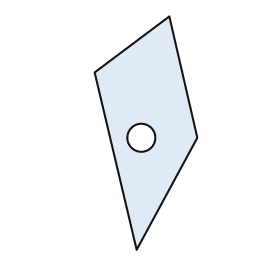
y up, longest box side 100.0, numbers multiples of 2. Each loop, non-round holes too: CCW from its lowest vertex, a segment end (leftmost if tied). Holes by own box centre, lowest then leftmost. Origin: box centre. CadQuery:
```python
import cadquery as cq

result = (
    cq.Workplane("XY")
    .moveTo(-4.0, -50.0)
    .lineTo(22.0, -2.0)
    .lineTo(10.0, 50.0)
    .lineTo(-22.0, 26.0)
    .close()
    .moveTo(-2.0, -2.0)
    .circle(6.0)
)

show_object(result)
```